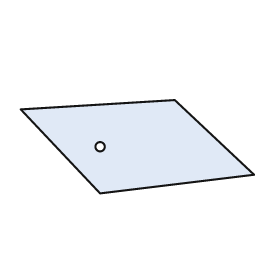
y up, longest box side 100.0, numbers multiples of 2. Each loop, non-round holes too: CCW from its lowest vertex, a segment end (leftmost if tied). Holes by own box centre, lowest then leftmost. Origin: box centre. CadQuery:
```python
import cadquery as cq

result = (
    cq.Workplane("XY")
    .moveTo(-16.0, -20.0)
    .lineTo(50.0, -12.0)
    .lineTo(16.0, 20.0)
    .lineTo(-50.0, 16.0)
    .close()
    .moveTo(-16.0, 0.0)
    .circle(2.0)
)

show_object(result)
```